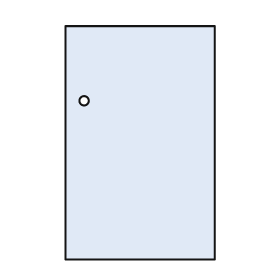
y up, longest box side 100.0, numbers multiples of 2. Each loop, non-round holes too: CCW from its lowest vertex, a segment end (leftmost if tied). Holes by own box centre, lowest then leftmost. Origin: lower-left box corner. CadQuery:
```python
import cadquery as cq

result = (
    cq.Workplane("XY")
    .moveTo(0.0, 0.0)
    .lineTo(64.0, 0.0)
    .lineTo(64.0, 100.0)
    .lineTo(0.0, 100.0)
    .close()
    .moveTo(8.0, 68.0)
    .circle(2.0)
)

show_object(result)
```